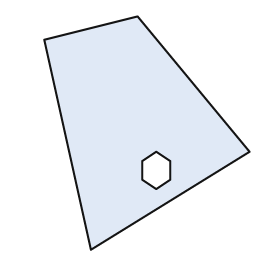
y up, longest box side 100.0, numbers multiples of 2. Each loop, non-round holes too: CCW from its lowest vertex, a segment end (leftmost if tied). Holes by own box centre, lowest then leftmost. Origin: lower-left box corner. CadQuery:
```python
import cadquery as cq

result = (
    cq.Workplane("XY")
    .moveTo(20.0, 0.0)
    .lineTo(88.0, 42.0)
    .lineTo(40.0, 100.0)
    .lineTo(0.0, 90.0)
    .close()
    .moveTo(48.0, 26.0)
    .lineTo(54.0, 30.0)
    .lineTo(54.0, 38.0)
    .lineTo(48.0, 42.0)
    .lineTo(42.0, 38.0)
    .lineTo(42.0, 30.0)
    .close()
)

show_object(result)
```